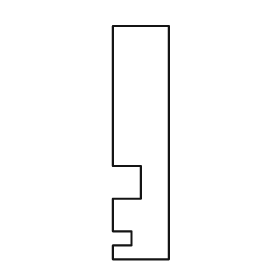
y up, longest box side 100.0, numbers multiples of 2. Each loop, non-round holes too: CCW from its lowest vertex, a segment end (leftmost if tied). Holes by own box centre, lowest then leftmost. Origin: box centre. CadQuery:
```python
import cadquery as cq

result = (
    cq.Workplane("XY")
    .moveTo(-12.0, -50.0)
    .lineTo(12.0, -50.0)
    .lineTo(12.0, 50.0)
    .lineTo(-12.0, 50.0)
    .lineTo(-12.0, -10.0)
    .lineTo(0.0, -10.0)
    .lineTo(0.0, -24.0)
    .lineTo(-12.0, -24.0)
    .lineTo(-12.0, -38.0)
    .lineTo(-4.0, -38.0)
    .lineTo(-4.0, -44.0)
    .lineTo(-12.0, -44.0)
    .close()
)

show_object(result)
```